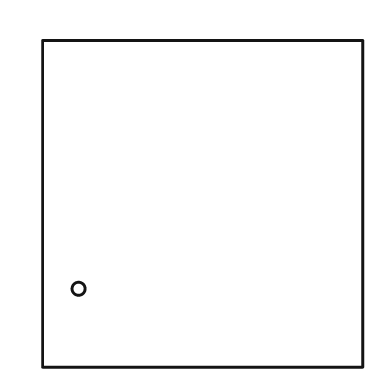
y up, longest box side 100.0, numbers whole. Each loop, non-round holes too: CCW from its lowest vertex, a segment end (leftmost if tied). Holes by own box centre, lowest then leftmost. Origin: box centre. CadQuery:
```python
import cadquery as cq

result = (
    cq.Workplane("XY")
    .moveTo(-49.0, -50.0)
    .lineTo(49.0, -50.0)
    .lineTo(49.0, 50.0)
    .lineTo(-49.0, 50.0)
    .close()
    .moveTo(-38.0, -26.0)
    .circle(2.0)
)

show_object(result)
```